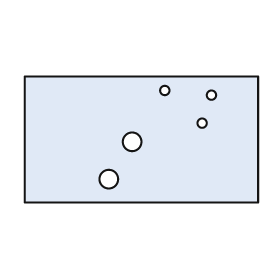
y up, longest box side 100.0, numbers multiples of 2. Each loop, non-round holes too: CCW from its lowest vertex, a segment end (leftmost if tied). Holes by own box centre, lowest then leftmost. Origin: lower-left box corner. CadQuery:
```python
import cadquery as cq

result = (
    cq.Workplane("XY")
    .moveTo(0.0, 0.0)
    .lineTo(100.0, 0.0)
    .lineTo(100.0, 54.0)
    .lineTo(0.0, 54.0)
    .close()
    .moveTo(36.0, 10.0)
    .circle(4.0)
    .moveTo(46.0, 26.0)
    .circle(4.0)
    .moveTo(76.0, 34.0)
    .circle(2.0)
    .moveTo(80.0, 46.0)
    .circle(2.0)
    .moveTo(60.0, 48.0)
    .circle(2.0)
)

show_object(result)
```